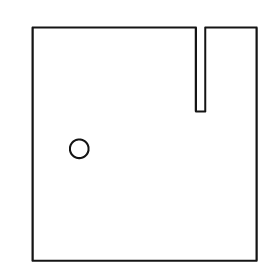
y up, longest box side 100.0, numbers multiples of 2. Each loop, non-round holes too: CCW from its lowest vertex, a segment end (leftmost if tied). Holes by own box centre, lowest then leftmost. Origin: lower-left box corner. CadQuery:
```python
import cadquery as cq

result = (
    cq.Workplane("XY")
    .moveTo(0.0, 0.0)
    .lineTo(96.0, 0.0)
    .lineTo(96.0, 100.0)
    .lineTo(74.0, 100.0)
    .lineTo(74.0, 64.0)
    .lineTo(70.0, 64.0)
    .lineTo(70.0, 100.0)
    .lineTo(0.0, 100.0)
    .close()
    .moveTo(20.0, 48.0)
    .circle(4.0)
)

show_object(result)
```